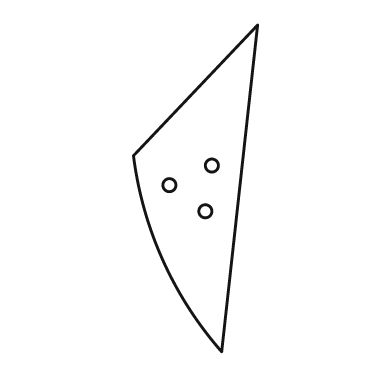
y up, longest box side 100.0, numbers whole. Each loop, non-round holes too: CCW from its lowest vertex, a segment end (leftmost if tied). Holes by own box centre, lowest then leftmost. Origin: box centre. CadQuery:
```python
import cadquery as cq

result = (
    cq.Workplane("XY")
    .moveTo(8.0, -50.0)
    .lineTo(19.0, 50.0)
    .lineTo(-19.0, 10.0)
    .threePointArc((-10.0, -22.0), (8.0, -50.0))
    .close()
    .moveTo(3.0, -7.0)
    .circle(2.0)
    .moveTo(-8.0, 1.0)
    .circle(2.0)
    .moveTo(5.0, 7.0)
    .circle(2.0)
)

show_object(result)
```